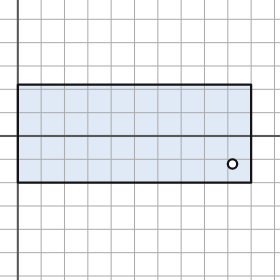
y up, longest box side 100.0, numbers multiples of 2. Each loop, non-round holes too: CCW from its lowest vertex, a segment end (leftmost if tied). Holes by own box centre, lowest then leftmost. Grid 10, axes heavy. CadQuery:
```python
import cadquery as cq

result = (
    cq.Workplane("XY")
    .moveTo(0.0, -20.0)
    .lineTo(100.0, -20.0)
    .lineTo(100.0, 22.0)
    .lineTo(0.0, 22.0)
    .close()
    .moveTo(92.0, -12.0)
    .circle(2.0)
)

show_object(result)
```